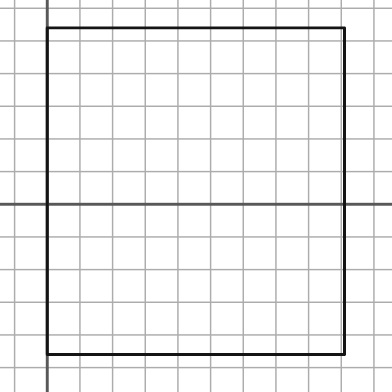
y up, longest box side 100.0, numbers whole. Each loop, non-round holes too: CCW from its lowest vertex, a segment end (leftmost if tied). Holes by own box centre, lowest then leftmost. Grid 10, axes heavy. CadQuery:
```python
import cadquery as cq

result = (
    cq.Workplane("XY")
    .moveTo(0.0, -46.0)
    .lineTo(91.0, -46.0)
    .lineTo(91.0, 54.0)
    .lineTo(0.0, 54.0)
    .close()
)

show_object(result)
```